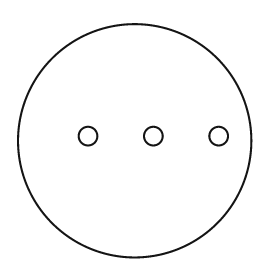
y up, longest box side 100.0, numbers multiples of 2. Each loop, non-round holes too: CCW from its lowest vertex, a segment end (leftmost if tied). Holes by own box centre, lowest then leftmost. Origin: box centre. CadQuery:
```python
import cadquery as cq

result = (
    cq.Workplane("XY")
    .moveTo(0.0, 0.0)
    .circle(50.0)
    .moveTo(-20.0, 2.0)
    .circle(4.0)
    .moveTo(8.0, 2.0)
    .circle(4.0)
    .moveTo(36.0, 2.0)
    .circle(4.0)
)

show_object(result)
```